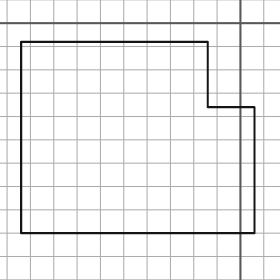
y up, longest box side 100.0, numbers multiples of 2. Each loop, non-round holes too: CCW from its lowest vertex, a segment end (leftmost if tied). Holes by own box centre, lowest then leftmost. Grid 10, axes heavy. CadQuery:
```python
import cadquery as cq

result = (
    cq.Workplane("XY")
    .moveTo(-94.0, -90.0)
    .lineTo(6.0, -90.0)
    .lineTo(6.0, -36.0)
    .lineTo(-14.0, -36.0)
    .lineTo(-14.0, -8.0)
    .lineTo(-94.0, -8.0)
    .close()
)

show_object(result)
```